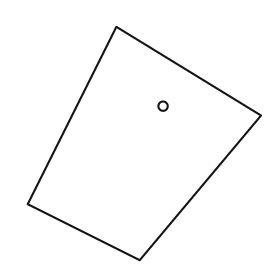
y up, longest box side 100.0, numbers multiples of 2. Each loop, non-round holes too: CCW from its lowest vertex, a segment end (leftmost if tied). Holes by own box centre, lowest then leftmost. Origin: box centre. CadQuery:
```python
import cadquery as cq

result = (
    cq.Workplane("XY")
    .moveTo(-2.0, -50.0)
    .lineTo(50.0, 12.0)
    .lineTo(-12.0, 50.0)
    .lineTo(-50.0, -26.0)
    .close()
    .moveTo(8.0, 16.0)
    .circle(2.0)
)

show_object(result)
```